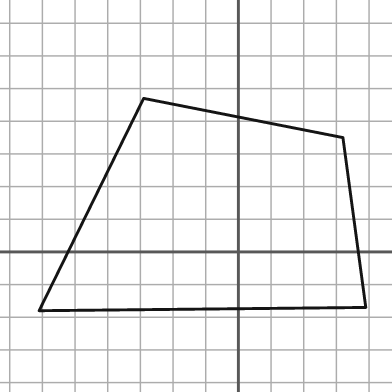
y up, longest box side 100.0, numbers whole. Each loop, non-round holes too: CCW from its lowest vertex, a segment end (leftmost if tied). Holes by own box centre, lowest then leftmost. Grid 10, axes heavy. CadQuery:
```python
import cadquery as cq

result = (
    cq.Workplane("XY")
    .moveTo(-61.0, -18.0)
    .lineTo(39.0, -17.0)
    .lineTo(32.0, 35.0)
    .lineTo(-29.0, 47.0)
    .close()
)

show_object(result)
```